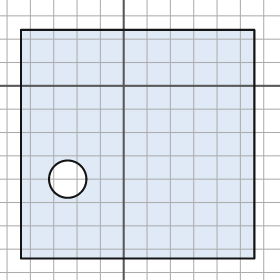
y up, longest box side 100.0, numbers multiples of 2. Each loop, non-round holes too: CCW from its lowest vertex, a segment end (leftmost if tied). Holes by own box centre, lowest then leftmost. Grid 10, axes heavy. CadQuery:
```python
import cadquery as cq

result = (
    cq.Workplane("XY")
    .moveTo(-44.0, -74.0)
    .lineTo(56.0, -74.0)
    .lineTo(56.0, 24.0)
    .lineTo(-44.0, 24.0)
    .close()
    .moveTo(-24.0, -40.0)
    .circle(8.0)
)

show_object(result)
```